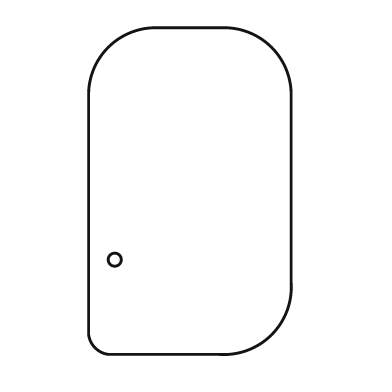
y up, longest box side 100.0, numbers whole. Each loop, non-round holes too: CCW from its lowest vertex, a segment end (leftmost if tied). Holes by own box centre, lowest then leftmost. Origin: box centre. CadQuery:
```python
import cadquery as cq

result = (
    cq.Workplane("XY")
    .moveTo(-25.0, -50.0)
    .lineTo(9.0, -50.0)
    .threePointArc((25.0, -44.0), (31.0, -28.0))
    .lineTo(31.0, 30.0)
    .threePointArc((25.0, 44.0), (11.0, 50.0))
    .lineTo(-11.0, 50.0)
    .threePointArc((-25.0, 44.0), (-31.0, 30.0))
    .lineTo(-31.0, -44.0)
    .threePointArc((-29.0, -48.0), (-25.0, -50.0))
    .close()
    .moveTo(-23.0, -21.0)
    .circle(2.0)
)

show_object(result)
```